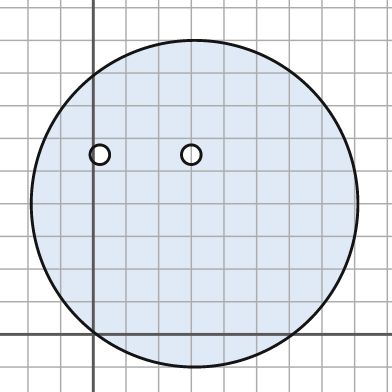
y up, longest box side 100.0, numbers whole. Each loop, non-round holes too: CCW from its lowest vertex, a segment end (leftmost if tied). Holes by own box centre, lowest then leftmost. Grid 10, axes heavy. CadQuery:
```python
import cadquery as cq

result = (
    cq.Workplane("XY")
    .moveTo(31.0, 40.0)
    .circle(50.0)
    .moveTo(2.0, 55.0)
    .circle(3.0)
    .moveTo(30.0, 55.0)
    .circle(3.0)
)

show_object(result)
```